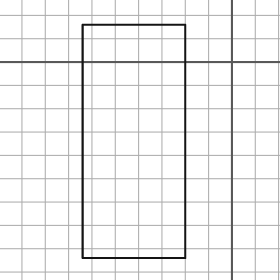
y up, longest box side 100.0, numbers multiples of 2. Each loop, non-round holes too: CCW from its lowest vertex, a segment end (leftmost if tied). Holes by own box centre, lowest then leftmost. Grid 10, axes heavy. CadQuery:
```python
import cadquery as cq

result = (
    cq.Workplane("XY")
    .moveTo(-64.0, -84.0)
    .lineTo(-20.0, -84.0)
    .lineTo(-20.0, 16.0)
    .lineTo(-64.0, 16.0)
    .close()
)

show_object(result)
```